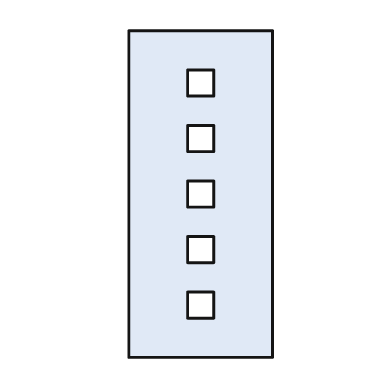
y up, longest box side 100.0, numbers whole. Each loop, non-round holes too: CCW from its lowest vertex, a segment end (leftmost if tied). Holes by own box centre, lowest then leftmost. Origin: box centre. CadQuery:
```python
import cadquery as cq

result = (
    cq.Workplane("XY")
    .moveTo(-22.0, -50.0)
    .lineTo(22.0, -50.0)
    .lineTo(22.0, 50.0)
    .lineTo(-22.0, 50.0)
    .close()
    .moveTo(-4.0, -38.0)
    .lineTo(4.0, -38.0)
    .lineTo(4.0, -30.0)
    .lineTo(-4.0, -30.0)
    .close()
    .moveTo(-4.0, -21.0)
    .lineTo(4.0, -21.0)
    .lineTo(4.0, -13.0)
    .lineTo(-4.0, -13.0)
    .close()
    .moveTo(-4.0, -4.0)
    .lineTo(4.0, -4.0)
    .lineTo(4.0, 4.0)
    .lineTo(-4.0, 4.0)
    .close()
    .moveTo(-4.0, 13.0)
    .lineTo(4.0, 13.0)
    .lineTo(4.0, 21.0)
    .lineTo(-4.0, 21.0)
    .close()
    .moveTo(-4.0, 30.0)
    .lineTo(4.0, 30.0)
    .lineTo(4.0, 38.0)
    .lineTo(-4.0, 38.0)
    .close()
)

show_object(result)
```